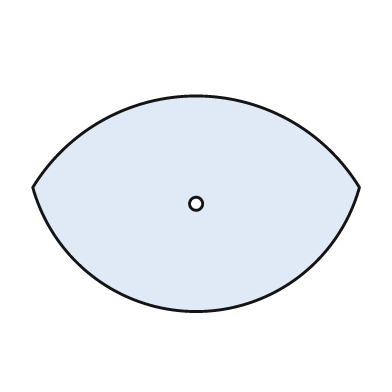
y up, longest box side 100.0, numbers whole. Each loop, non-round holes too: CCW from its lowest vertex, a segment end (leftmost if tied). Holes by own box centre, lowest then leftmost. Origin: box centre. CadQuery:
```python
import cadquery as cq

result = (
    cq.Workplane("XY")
    .moveTo(-50.0, 5.0)
    .threePointArc((0.0, -33.0), (50.0, 5.0))
    .threePointArc((0.0, 33.0), (-50.0, 5.0))
    .close()
    .moveTo(0.0, 0.0)
    .circle(2.0)
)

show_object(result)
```